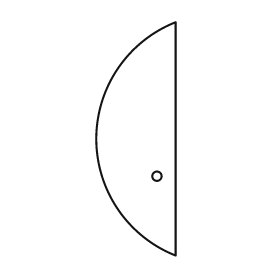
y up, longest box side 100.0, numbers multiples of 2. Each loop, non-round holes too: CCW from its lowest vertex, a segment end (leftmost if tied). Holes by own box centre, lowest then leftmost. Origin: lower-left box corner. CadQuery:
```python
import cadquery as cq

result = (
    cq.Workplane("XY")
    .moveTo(34.0, 0.0)
    .lineTo(34.0, 100.0)
    .threePointArc((0.0, 50.0), (34.0, 0.0))
    .close()
    .moveTo(26.0, 34.0)
    .circle(2.0)
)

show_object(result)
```